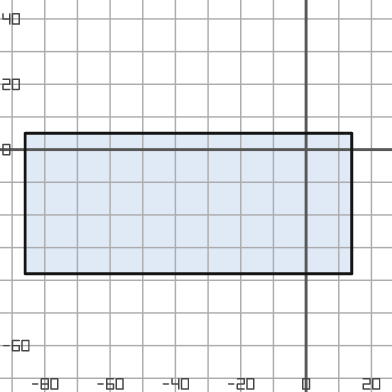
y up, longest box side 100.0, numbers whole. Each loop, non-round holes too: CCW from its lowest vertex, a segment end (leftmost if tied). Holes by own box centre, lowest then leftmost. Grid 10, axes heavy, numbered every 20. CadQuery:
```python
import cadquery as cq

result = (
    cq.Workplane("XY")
    .moveTo(-86.0, -38.0)
    .lineTo(14.0, -38.0)
    .lineTo(14.0, 5.0)
    .lineTo(-86.0, 5.0)
    .close()
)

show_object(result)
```